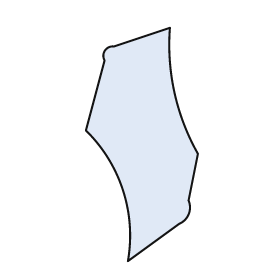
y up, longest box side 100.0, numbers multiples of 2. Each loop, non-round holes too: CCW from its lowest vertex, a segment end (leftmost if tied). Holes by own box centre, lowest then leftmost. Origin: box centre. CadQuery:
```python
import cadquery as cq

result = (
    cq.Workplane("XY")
    .moveTo(-6.0, -50.0)
    .lineTo(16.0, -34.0)
    .threePointArc((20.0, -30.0), (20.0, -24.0))
    .lineTo(24.0, -4.0)
    .threePointArc((14.0, 22.0), (12.0, 50.0))
    .lineTo(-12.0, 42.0)
    .threePointArc((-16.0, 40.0), (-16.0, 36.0))
    .lineTo(-24.0, 6.0)
    .threePointArc((-8.0, -20.0), (-6.0, -50.0))
    .close()
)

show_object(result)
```